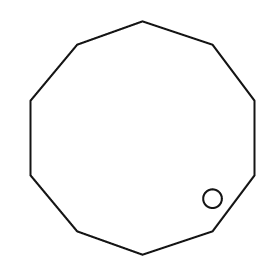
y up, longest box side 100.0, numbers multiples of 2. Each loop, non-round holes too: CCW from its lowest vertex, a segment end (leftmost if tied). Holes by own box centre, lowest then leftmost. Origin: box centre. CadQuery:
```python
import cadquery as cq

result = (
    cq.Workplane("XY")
    .moveTo(0.0, -50.0)
    .lineTo(30.0, -40.0)
    .lineTo(48.0, -16.0)
    .lineTo(48.0, 16.0)
    .lineTo(30.0, 40.0)
    .lineTo(0.0, 50.0)
    .lineTo(-28.0, 40.0)
    .lineTo(-48.0, 16.0)
    .lineTo(-48.0, -16.0)
    .lineTo(-28.0, -40.0)
    .close()
    .moveTo(30.0, -26.0)
    .circle(4.0)
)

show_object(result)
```